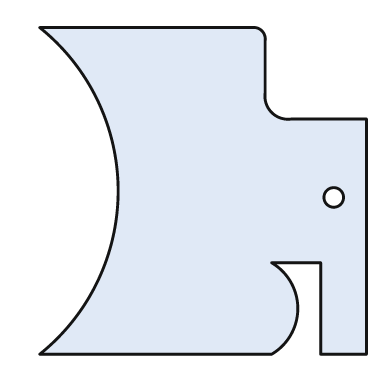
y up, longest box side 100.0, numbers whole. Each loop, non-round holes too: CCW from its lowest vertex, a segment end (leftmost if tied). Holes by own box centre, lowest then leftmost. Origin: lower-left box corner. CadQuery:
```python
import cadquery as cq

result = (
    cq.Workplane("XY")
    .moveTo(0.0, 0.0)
    .lineTo(71.0, 0.0)
    .threePointArc((79.0, 14.0), (71.0, 28.0))
    .lineTo(86.0, 28.0)
    .lineTo(86.0, 0.0)
    .lineTo(100.0, 0.0)
    .lineTo(100.0, 72.0)
    .lineTo(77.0, 72.0)
    .threePointArc((71.0, 74.0), (69.0, 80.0))
    .lineTo(69.0, 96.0)
    .threePointArc((68.0, 99.0), (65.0, 100.0))
    .lineTo(0.0, 100.0)
    .threePointArc((24.0, 50.0), (0.0, 0.0))
    .close()
    .moveTo(90.0, 48.0)
    .circle(3.0)
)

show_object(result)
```